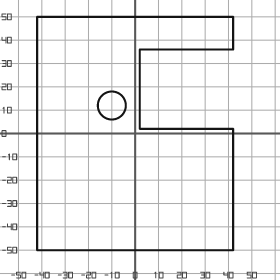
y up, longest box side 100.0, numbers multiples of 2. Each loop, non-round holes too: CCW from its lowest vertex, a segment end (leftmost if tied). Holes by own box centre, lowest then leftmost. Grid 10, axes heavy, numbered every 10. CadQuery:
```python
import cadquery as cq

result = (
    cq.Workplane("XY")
    .moveTo(-42.0, -50.0)
    .lineTo(42.0, -50.0)
    .lineTo(42.0, 2.0)
    .lineTo(2.0, 2.0)
    .lineTo(2.0, 36.0)
    .lineTo(42.0, 36.0)
    .lineTo(42.0, 50.0)
    .lineTo(-42.0, 50.0)
    .close()
    .moveTo(-10.0, 12.0)
    .circle(6.0)
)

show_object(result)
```